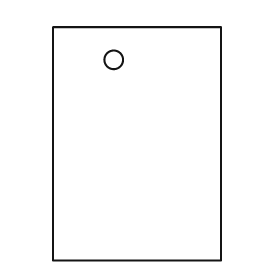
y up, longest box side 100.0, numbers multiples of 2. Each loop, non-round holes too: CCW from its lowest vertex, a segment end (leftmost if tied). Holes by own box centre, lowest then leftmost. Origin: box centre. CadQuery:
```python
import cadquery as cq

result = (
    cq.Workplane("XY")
    .moveTo(-36.0, -50.0)
    .lineTo(36.0, -50.0)
    .lineTo(36.0, 50.0)
    .lineTo(-36.0, 50.0)
    .close()
    .moveTo(-10.0, 36.0)
    .circle(4.0)
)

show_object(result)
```